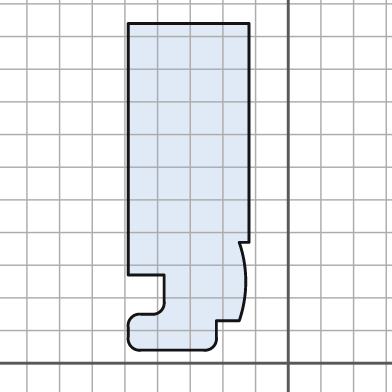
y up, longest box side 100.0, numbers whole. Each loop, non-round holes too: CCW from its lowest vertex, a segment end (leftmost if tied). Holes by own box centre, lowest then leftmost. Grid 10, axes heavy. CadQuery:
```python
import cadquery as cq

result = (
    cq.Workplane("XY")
    .moveTo(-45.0, 4.0)
    .lineTo(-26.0, 4.0)
    .threePointArc((-23.0, 5.0), (-22.0, 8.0))
    .lineTo(-22.0, 13.0)
    .lineTo(-15.0, 13.0)
    .threePointArc((-13.0, 25.0), (-15.0, 37.0))
    .lineTo(-12.0, 37.0)
    .lineTo(-12.0, 104.0)
    .lineTo(-49.0, 104.0)
    .lineTo(-49.0, 27.0)
    .lineTo(-38.0, 27.0)
    .lineTo(-38.0, 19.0)
    .threePointArc((-39.0, 16.0), (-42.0, 15.0))
    .lineTo(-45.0, 15.0)
    .threePointArc((-48.0, 14.0), (-49.0, 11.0))
    .lineTo(-49.0, 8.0)
    .threePointArc((-48.0, 5.0), (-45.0, 4.0))
    .close()
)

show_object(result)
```